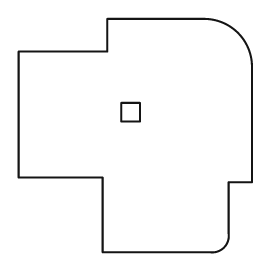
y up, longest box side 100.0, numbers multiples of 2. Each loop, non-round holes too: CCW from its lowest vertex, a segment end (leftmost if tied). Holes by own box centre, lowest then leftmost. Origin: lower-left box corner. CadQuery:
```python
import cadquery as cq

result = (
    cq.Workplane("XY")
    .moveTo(36.0, 0.0)
    .lineTo(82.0, 0.0)
    .threePointArc((88.0, 2.0), (90.0, 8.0))
    .lineTo(90.0, 30.0)
    .lineTo(100.0, 30.0)
    .lineTo(100.0, 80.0)
    .threePointArc((94.0, 94.0), (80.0, 100.0))
    .lineTo(38.0, 100.0)
    .lineTo(38.0, 86.0)
    .lineTo(0.0, 86.0)
    .lineTo(0.0, 32.0)
    .lineTo(36.0, 32.0)
    .close()
    .moveTo(44.0, 56.0)
    .lineTo(52.0, 56.0)
    .lineTo(52.0, 64.0)
    .lineTo(44.0, 64.0)
    .close()
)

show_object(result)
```